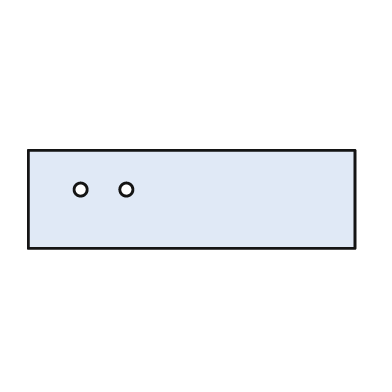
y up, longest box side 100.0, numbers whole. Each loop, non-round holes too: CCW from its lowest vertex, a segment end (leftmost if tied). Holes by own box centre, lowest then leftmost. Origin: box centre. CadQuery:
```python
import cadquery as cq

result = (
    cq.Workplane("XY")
    .moveTo(-50.0, -15.0)
    .lineTo(50.0, -15.0)
    .lineTo(50.0, 15.0)
    .lineTo(-50.0, 15.0)
    .close()
    .moveTo(-34.0, 3.0)
    .circle(2.0)
    .moveTo(-20.0, 3.0)
    .circle(2.0)
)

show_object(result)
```